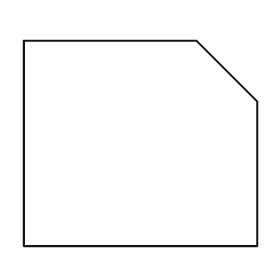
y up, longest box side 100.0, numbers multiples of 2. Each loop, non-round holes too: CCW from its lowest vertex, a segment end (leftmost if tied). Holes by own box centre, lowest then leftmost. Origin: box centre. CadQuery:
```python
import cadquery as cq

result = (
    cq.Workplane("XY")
    .moveTo(-50.0, -44.0)
    .lineTo(50.0, -44.0)
    .lineTo(50.0, 18.0)
    .lineTo(24.0, 44.0)
    .lineTo(-50.0, 44.0)
    .close()
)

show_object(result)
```